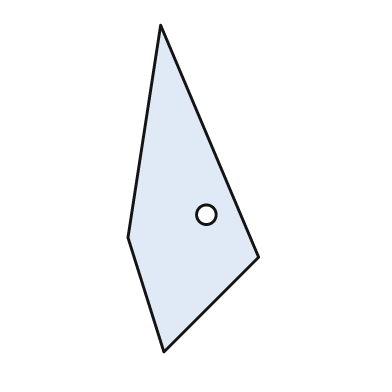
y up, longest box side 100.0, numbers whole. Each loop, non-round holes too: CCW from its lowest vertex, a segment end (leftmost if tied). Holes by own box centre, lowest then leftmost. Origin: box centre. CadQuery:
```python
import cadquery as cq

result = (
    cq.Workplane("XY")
    .moveTo(-9.0, -50.0)
    .lineTo(20.0, -21.0)
    .lineTo(-10.0, 50.0)
    .lineTo(-20.0, -15.0)
    .close()
    .moveTo(4.0, -8.0)
    .circle(3.0)
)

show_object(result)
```